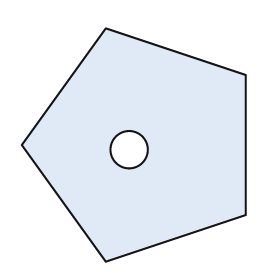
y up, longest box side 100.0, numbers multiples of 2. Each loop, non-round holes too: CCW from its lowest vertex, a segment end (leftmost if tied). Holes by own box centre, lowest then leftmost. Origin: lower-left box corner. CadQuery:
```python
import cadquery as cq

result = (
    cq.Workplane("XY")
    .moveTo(36.0, 0.0)
    .lineTo(96.0, 20.0)
    .lineTo(96.0, 80.0)
    .lineTo(36.0, 100.0)
    .lineTo(0.0, 50.0)
    .close()
    .moveTo(46.0, 48.0)
    .circle(8.0)
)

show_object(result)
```